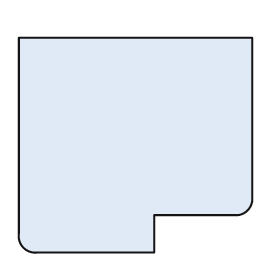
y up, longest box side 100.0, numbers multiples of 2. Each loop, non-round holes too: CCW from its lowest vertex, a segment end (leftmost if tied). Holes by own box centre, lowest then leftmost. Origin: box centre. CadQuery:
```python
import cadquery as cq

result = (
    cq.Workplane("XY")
    .moveTo(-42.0, -46.0)
    .lineTo(8.0, -46.0)
    .lineTo(8.0, -30.0)
    .lineTo(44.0, -30.0)
    .threePointArc((48.0, -28.0), (50.0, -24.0))
    .lineTo(50.0, 46.0)
    .lineTo(-50.0, 46.0)
    .lineTo(-50.0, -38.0)
    .threePointArc((-48.0, -44.0), (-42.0, -46.0))
    .close()
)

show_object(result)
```